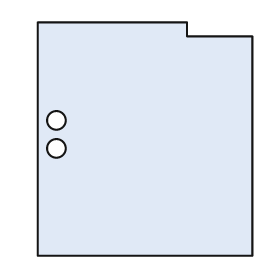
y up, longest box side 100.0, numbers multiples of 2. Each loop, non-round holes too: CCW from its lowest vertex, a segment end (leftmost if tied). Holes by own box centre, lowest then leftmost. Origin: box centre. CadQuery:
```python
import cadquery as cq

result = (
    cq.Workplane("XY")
    .moveTo(-46.0, -50.0)
    .lineTo(46.0, -50.0)
    .lineTo(46.0, 44.0)
    .lineTo(18.0, 44.0)
    .lineTo(18.0, 50.0)
    .lineTo(-46.0, 50.0)
    .close()
    .moveTo(-38.0, -4.0)
    .circle(4.0)
    .moveTo(-38.0, 8.0)
    .circle(4.0)
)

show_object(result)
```